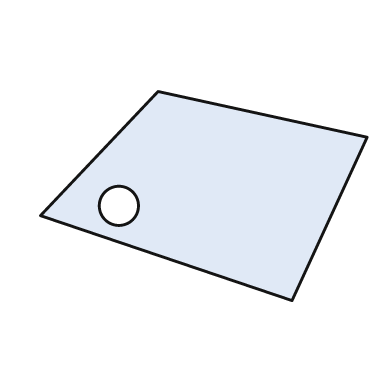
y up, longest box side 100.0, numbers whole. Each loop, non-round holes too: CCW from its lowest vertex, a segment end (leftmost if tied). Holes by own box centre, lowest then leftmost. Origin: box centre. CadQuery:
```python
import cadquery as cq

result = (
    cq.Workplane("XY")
    .moveTo(27.0, -32.0)
    .lineTo(50.0, 18.0)
    .lineTo(-14.0, 32.0)
    .lineTo(-50.0, -6.0)
    .close()
    .moveTo(-26.0, -3.0)
    .circle(6.0)
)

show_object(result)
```